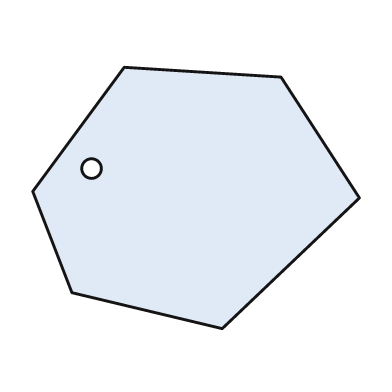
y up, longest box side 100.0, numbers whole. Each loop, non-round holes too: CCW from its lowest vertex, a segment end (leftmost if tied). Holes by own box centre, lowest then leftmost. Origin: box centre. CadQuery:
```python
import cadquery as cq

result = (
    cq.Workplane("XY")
    .moveTo(8.0, -40.0)
    .lineTo(50.0, 0.0)
    .lineTo(26.0, 37.0)
    .lineTo(-22.0, 40.0)
    .lineTo(-50.0, 2.0)
    .lineTo(-38.0, -29.0)
    .close()
    .moveTo(-32.0, 9.0)
    .circle(3.0)
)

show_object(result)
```